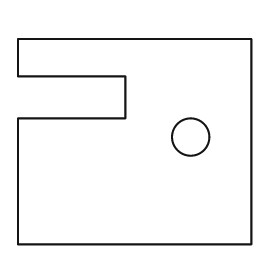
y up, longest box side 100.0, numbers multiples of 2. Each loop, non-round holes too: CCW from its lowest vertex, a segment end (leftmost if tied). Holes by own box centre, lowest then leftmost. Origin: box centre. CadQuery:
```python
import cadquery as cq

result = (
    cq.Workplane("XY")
    .moveTo(-50.0, -44.0)
    .lineTo(50.0, -44.0)
    .lineTo(50.0, 44.0)
    .lineTo(-50.0, 44.0)
    .lineTo(-50.0, 28.0)
    .lineTo(-4.0, 28.0)
    .lineTo(-4.0, 10.0)
    .lineTo(-50.0, 10.0)
    .close()
    .moveTo(24.0, 2.0)
    .circle(8.0)
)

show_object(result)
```